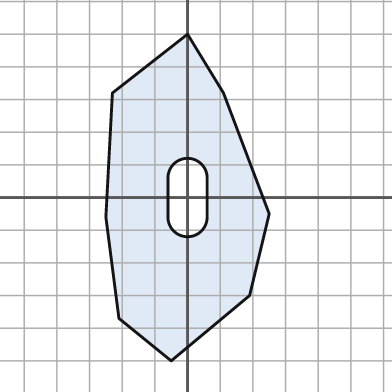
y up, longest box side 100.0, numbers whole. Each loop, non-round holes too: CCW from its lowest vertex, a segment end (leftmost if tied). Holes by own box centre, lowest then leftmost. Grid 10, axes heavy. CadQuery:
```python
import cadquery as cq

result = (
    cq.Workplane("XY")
    .moveTo(-5.0, -50.0)
    .lineTo(19.0, -30.0)
    .lineTo(25.0, -5.0)
    .lineTo(11.0, 32.0)
    .lineTo(0.0, 50.0)
    .lineTo(-23.0, 32.0)
    .lineTo(-25.0, -6.0)
    .lineTo(-21.0, -37.0)
    .close()
    .moveTo(-6.0, -6.0)
    .threePointArc((0.0, -12.0), (6.0, -6.0))
    .lineTo(6.0, 6.0)
    .threePointArc((0.0, 12.0), (-6.0, 6.0))
    .close()
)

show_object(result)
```